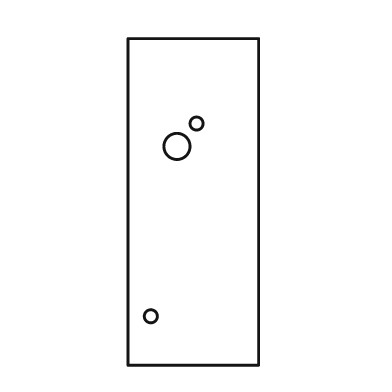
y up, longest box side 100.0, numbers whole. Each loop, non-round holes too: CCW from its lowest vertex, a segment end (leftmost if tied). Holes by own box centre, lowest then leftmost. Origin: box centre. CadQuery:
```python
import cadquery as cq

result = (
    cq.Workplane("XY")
    .moveTo(-20.0, -50.0)
    .lineTo(20.0, -50.0)
    .lineTo(20.0, 50.0)
    .lineTo(-20.0, 50.0)
    .close()
    .moveTo(-13.0, -35.0)
    .circle(2.0)
    .moveTo(-5.0, 17.0)
    .circle(4.0)
    .moveTo(1.0, 24.0)
    .circle(2.0)
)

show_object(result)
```